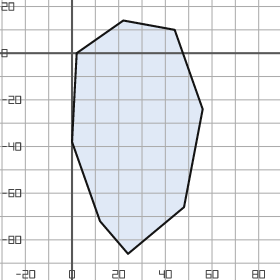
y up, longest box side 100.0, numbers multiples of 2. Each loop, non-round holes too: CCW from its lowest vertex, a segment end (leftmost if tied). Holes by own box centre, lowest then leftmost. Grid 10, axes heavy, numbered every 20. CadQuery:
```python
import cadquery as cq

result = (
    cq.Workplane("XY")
    .moveTo(24.0, -86.0)
    .lineTo(48.0, -66.0)
    .lineTo(56.0, -24.0)
    .lineTo(44.0, 10.0)
    .lineTo(22.0, 14.0)
    .lineTo(2.0, 0.0)
    .lineTo(0.0, -38.0)
    .lineTo(12.0, -72.0)
    .close()
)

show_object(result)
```